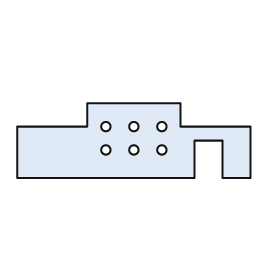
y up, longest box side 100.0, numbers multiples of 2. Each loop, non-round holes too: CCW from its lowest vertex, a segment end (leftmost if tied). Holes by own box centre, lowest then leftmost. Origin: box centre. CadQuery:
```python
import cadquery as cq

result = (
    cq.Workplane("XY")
    .moveTo(-50.0, -16.0)
    .lineTo(26.0, -16.0)
    .lineTo(26.0, 0.0)
    .lineTo(38.0, 0.0)
    .lineTo(38.0, -16.0)
    .lineTo(50.0, -16.0)
    .lineTo(50.0, 6.0)
    .lineTo(20.0, 6.0)
    .lineTo(20.0, 16.0)
    .lineTo(-20.0, 16.0)
    .lineTo(-20.0, 6.0)
    .lineTo(-50.0, 6.0)
    .close()
    .moveTo(-12.0, -4.0)
    .circle(2.0)
    .moveTo(0.0, -4.0)
    .circle(2.0)
    .moveTo(12.0, -4.0)
    .circle(2.0)
    .moveTo(-12.0, 6.0)
    .circle(2.0)
    .moveTo(0.0, 6.0)
    .circle(2.0)
    .moveTo(12.0, 6.0)
    .circle(2.0)
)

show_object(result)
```